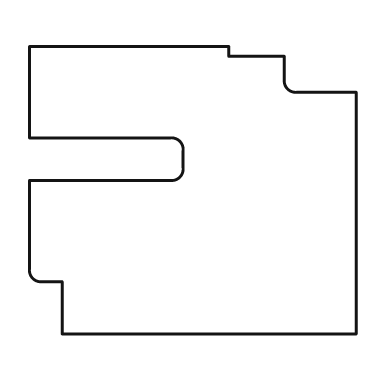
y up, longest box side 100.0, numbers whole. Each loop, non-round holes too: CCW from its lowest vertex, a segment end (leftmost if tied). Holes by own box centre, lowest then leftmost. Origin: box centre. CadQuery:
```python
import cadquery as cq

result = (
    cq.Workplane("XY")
    .moveTo(-40.0, -44.0)
    .lineTo(50.0, -44.0)
    .lineTo(50.0, 30.0)
    .lineTo(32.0, 30.0)
    .threePointArc((29.0, 31.0), (28.0, 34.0))
    .lineTo(28.0, 41.0)
    .lineTo(11.0, 41.0)
    .lineTo(11.0, 44.0)
    .lineTo(-50.0, 44.0)
    .lineTo(-50.0, 16.0)
    .lineTo(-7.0, 16.0)
    .threePointArc((-4.0, 15.0), (-3.0, 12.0))
    .lineTo(-3.0, 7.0)
    .threePointArc((-4.0, 4.0), (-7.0, 3.0))
    .lineTo(-50.0, 3.0)
    .lineTo(-50.0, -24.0)
    .threePointArc((-49.0, -27.0), (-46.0, -28.0))
    .lineTo(-40.0, -28.0)
    .close()
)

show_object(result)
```